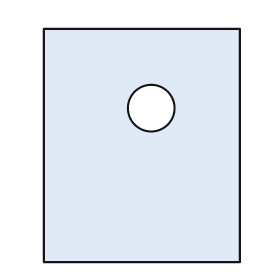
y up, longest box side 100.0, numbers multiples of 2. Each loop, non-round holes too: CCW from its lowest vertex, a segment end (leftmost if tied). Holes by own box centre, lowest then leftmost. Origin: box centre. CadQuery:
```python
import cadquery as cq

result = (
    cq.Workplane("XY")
    .moveTo(-42.0, -50.0)
    .lineTo(42.0, -50.0)
    .lineTo(42.0, 50.0)
    .lineTo(-42.0, 50.0)
    .close()
    .moveTo(4.0, 16.0)
    .circle(10.0)
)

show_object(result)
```